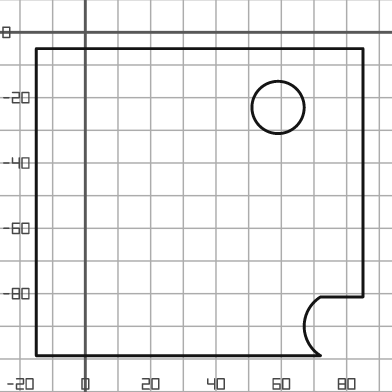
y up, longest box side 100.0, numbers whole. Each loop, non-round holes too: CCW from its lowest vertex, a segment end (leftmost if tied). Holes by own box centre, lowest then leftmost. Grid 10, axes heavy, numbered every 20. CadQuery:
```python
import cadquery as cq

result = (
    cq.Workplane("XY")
    .moveTo(-15.0, -99.0)
    .lineTo(72.0, -99.0)
    .threePointArc((67.0, -90.0), (72.0, -81.0))
    .lineTo(85.0, -81.0)
    .lineTo(85.0, -5.0)
    .lineTo(-15.0, -5.0)
    .close()
    .moveTo(59.0, -23.0)
    .circle(8.0)
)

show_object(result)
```